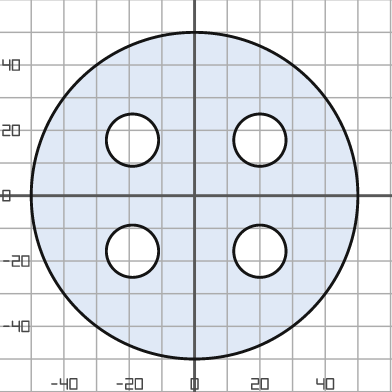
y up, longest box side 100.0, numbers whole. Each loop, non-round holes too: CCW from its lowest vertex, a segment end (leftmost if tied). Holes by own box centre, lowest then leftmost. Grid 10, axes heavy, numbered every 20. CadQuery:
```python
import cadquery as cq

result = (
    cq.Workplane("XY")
    .moveTo(0.0, 0.0)
    .circle(50.0)
    .moveTo(-19.0, -17.0)
    .circle(8.0)
    .moveTo(20.0, -17.0)
    .circle(8.0)
    .moveTo(-19.0, 17.0)
    .circle(8.0)
    .moveTo(20.0, 17.0)
    .circle(8.0)
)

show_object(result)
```